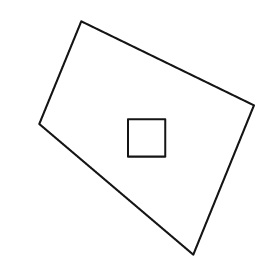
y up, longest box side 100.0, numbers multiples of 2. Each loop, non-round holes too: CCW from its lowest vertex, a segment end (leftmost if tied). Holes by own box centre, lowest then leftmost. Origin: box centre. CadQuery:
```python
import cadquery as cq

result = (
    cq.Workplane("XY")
    .moveTo(20.0, -50.0)
    .lineTo(46.0, 14.0)
    .lineTo(-28.0, 50.0)
    .lineTo(-46.0, 6.0)
    .close()
    .moveTo(-8.0, -8.0)
    .lineTo(8.0, -8.0)
    .lineTo(8.0, 8.0)
    .lineTo(-8.0, 8.0)
    .close()
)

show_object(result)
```